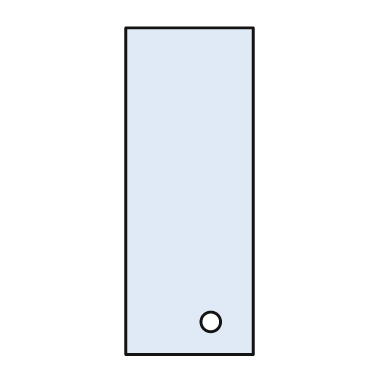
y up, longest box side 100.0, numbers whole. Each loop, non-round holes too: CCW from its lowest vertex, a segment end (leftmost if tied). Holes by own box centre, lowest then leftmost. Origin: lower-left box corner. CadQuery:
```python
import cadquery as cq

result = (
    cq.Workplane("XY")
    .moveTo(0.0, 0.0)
    .lineTo(39.0, 0.0)
    .lineTo(39.0, 100.0)
    .lineTo(0.0, 100.0)
    .close()
    .moveTo(26.0, 10.0)
    .circle(3.0)
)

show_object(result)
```